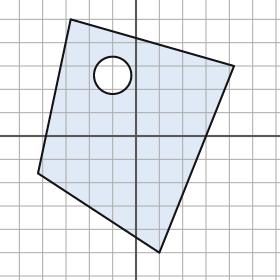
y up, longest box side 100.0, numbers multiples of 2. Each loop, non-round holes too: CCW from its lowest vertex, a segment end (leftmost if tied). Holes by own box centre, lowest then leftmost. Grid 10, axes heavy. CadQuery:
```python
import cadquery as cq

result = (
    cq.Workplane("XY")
    .moveTo(10.0, -50.0)
    .lineTo(42.0, 30.0)
    .lineTo(-28.0, 50.0)
    .lineTo(-42.0, -16.0)
    .close()
    .moveTo(-10.0, 26.0)
    .circle(8.0)
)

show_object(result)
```